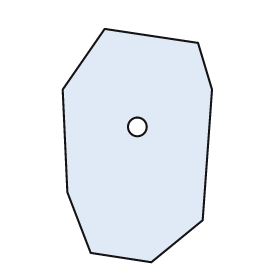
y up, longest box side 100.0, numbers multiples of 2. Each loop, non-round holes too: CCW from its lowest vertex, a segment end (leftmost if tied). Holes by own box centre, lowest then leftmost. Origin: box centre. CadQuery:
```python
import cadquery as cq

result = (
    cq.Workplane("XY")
    .moveTo(6.0, -50.0)
    .lineTo(28.0, -32.0)
    .lineTo(32.0, 24.0)
    .lineTo(26.0, 44.0)
    .lineTo(-14.0, 50.0)
    .lineTo(-32.0, 24.0)
    .lineTo(-30.0, -20.0)
    .lineTo(-20.0, -46.0)
    .close()
    .moveTo(0.0, 8.0)
    .circle(4.0)
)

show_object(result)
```